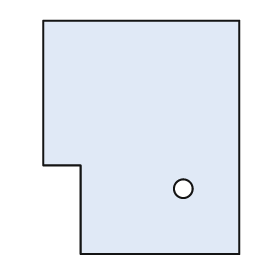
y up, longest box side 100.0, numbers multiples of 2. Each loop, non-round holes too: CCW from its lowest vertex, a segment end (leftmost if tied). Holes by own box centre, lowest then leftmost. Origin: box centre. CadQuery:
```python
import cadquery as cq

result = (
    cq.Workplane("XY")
    .moveTo(-26.0, -50.0)
    .lineTo(42.0, -50.0)
    .lineTo(42.0, 50.0)
    .lineTo(-42.0, 50.0)
    .lineTo(-42.0, -12.0)
    .lineTo(-26.0, -12.0)
    .close()
    .moveTo(18.0, -22.0)
    .circle(4.0)
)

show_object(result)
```